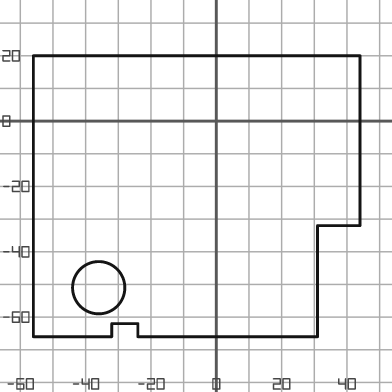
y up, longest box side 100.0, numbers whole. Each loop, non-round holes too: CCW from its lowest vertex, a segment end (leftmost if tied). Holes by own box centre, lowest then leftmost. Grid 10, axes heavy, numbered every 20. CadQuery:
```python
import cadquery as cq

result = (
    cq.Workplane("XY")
    .moveTo(-56.0, -66.0)
    .lineTo(-32.0, -66.0)
    .lineTo(-32.0, -62.0)
    .lineTo(-24.0, -62.0)
    .lineTo(-24.0, -66.0)
    .lineTo(31.0, -66.0)
    .lineTo(31.0, -32.0)
    .lineTo(44.0, -32.0)
    .lineTo(44.0, 20.0)
    .lineTo(-56.0, 20.0)
    .close()
    .moveTo(-36.0, -51.0)
    .circle(8.0)
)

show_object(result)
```